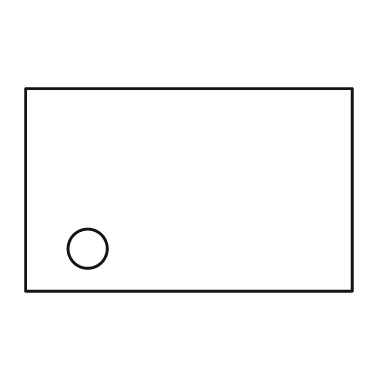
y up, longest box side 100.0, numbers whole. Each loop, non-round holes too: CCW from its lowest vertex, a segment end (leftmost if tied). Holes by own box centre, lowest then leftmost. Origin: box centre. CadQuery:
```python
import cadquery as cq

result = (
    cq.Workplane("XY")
    .moveTo(-50.0, -31.0)
    .lineTo(50.0, -31.0)
    .lineTo(50.0, 31.0)
    .lineTo(-50.0, 31.0)
    .close()
    .moveTo(-31.0, -18.0)
    .circle(6.0)
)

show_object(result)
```